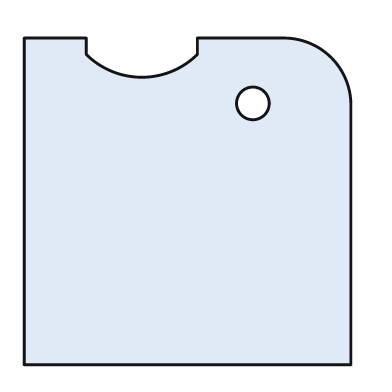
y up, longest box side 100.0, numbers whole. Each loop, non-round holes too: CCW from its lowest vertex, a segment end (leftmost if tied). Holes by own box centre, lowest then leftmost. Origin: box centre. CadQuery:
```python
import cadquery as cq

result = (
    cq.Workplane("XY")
    .moveTo(-50.0, -50.0)
    .lineTo(50.0, -50.0)
    .lineTo(50.0, 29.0)
    .threePointArc((44.0, 44.0), (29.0, 50.0))
    .lineTo(3.0, 50.0)
    .lineTo(3.0, 45.0)
    .threePointArc((-14.0, 38.0), (-31.0, 45.0))
    .lineTo(-31.0, 50.0)
    .lineTo(-50.0, 50.0)
    .close()
    .moveTo(20.0, 30.0)
    .circle(5.0)
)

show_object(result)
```